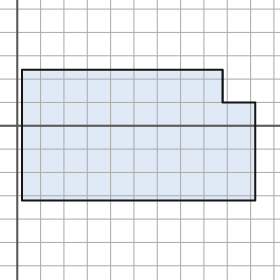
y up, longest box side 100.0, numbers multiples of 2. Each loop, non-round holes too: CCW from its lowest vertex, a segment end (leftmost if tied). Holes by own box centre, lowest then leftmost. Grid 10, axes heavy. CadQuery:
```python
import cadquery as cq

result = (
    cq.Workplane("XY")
    .moveTo(2.0, -32.0)
    .lineTo(102.0, -32.0)
    .lineTo(102.0, 10.0)
    .lineTo(88.0, 10.0)
    .lineTo(88.0, 24.0)
    .lineTo(2.0, 24.0)
    .close()
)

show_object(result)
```